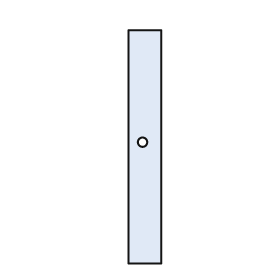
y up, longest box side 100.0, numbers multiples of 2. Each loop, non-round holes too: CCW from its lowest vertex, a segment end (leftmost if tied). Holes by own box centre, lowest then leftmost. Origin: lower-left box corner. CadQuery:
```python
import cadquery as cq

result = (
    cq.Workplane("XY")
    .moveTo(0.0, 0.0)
    .lineTo(14.0, 0.0)
    .lineTo(14.0, 100.0)
    .lineTo(0.0, 100.0)
    .close()
    .moveTo(6.0, 52.0)
    .circle(2.0)
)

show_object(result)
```